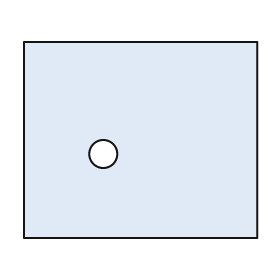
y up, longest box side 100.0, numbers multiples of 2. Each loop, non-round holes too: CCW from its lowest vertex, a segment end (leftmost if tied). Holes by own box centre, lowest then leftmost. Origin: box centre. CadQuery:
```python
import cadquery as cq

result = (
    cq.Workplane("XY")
    .moveTo(-50.0, -42.0)
    .lineTo(50.0, -42.0)
    .lineTo(50.0, 42.0)
    .lineTo(-50.0, 42.0)
    .close()
    .moveTo(-16.0, -6.0)
    .circle(6.0)
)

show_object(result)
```